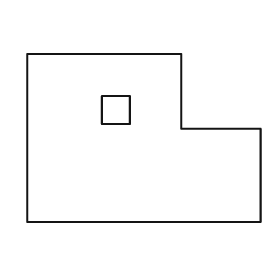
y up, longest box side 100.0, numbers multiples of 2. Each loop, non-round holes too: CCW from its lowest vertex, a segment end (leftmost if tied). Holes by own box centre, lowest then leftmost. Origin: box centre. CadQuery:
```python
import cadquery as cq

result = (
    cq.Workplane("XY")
    .moveTo(-50.0, -36.0)
    .lineTo(50.0, -36.0)
    .lineTo(50.0, 4.0)
    .lineTo(16.0, 4.0)
    .lineTo(16.0, 36.0)
    .lineTo(-50.0, 36.0)
    .close()
    .moveTo(-18.0, 6.0)
    .lineTo(-6.0, 6.0)
    .lineTo(-6.0, 18.0)
    .lineTo(-18.0, 18.0)
    .close()
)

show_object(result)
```